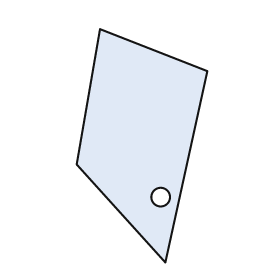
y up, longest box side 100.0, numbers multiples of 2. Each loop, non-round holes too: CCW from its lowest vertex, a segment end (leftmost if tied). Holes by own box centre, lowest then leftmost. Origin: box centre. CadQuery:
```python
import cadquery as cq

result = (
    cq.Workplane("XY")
    .moveTo(10.0, -50.0)
    .lineTo(28.0, 32.0)
    .lineTo(-18.0, 50.0)
    .lineTo(-28.0, -8.0)
    .close()
    .moveTo(8.0, -22.0)
    .circle(4.0)
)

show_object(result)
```